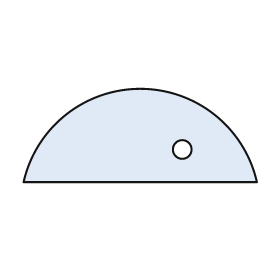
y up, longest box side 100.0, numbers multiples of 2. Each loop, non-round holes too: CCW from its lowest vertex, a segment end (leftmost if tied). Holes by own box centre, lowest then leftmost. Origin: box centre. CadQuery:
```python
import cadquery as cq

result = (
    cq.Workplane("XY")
    .moveTo(-50.0, -20.0)
    .lineTo(50.0, -20.0)
    .threePointArc((0.0, 20.0), (-50.0, -20.0))
    .close()
    .moveTo(18.0, -6.0)
    .circle(4.0)
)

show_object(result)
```